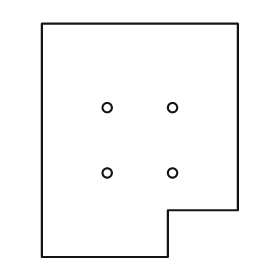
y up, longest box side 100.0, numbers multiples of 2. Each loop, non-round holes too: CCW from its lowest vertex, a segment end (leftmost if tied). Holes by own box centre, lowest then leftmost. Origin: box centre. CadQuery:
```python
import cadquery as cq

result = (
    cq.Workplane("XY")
    .moveTo(-42.0, -50.0)
    .lineTo(12.0, -50.0)
    .lineTo(12.0, -30.0)
    .lineTo(42.0, -30.0)
    .lineTo(42.0, 50.0)
    .lineTo(-42.0, 50.0)
    .close()
    .moveTo(-14.0, -14.0)
    .circle(2.0)
    .moveTo(14.0, -14.0)
    .circle(2.0)
    .moveTo(-14.0, 14.0)
    .circle(2.0)
    .moveTo(14.0, 14.0)
    .circle(2.0)
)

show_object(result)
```